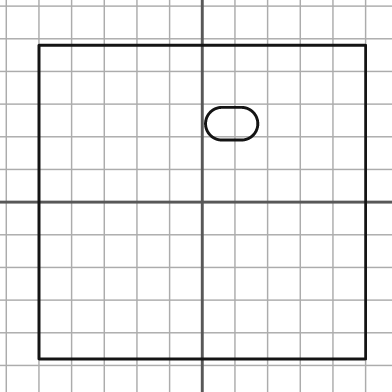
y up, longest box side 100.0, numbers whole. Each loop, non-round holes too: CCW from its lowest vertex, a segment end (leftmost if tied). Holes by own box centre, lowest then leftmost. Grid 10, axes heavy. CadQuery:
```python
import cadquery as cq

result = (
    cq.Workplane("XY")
    .moveTo(-50.0, -48.0)
    .lineTo(50.0, -48.0)
    .lineTo(50.0, 48.0)
    .lineTo(-50.0, 48.0)
    .close()
    .moveTo(6.0, 19.0)
    .lineTo(12.0, 19.0)
    .threePointArc((17.0, 24.0), (12.0, 29.0))
    .lineTo(6.0, 29.0)
    .threePointArc((1.0, 24.0), (6.0, 19.0))
    .close()
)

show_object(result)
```